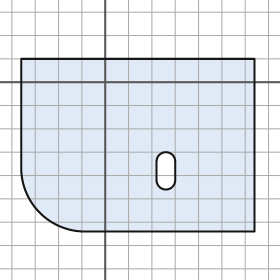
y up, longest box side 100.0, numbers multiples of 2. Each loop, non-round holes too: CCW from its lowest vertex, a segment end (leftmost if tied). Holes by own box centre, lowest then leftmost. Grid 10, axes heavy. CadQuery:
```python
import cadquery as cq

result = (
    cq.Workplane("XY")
    .moveTo(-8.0, -64.0)
    .lineTo(64.0, -64.0)
    .lineTo(64.0, 10.0)
    .lineTo(-36.0, 10.0)
    .lineTo(-36.0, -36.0)
    .threePointArc((-28.0, -56.0), (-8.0, -64.0))
    .close()
    .moveTo(22.0, -42.0)
    .threePointArc((26.0, -46.0), (30.0, -42.0))
    .lineTo(30.0, -34.0)
    .threePointArc((26.0, -30.0), (22.0, -34.0))
    .close()
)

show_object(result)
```